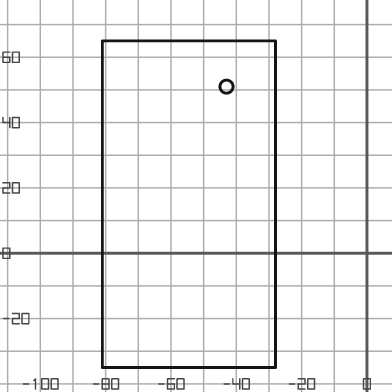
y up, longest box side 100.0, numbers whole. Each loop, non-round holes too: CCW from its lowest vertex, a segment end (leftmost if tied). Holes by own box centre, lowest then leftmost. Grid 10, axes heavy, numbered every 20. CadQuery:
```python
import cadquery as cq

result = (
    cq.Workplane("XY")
    .moveTo(-81.0, -35.0)
    .lineTo(-28.0, -35.0)
    .lineTo(-28.0, 65.0)
    .lineTo(-81.0, 65.0)
    .close()
    .moveTo(-43.0, 51.0)
    .circle(2.0)
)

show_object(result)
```